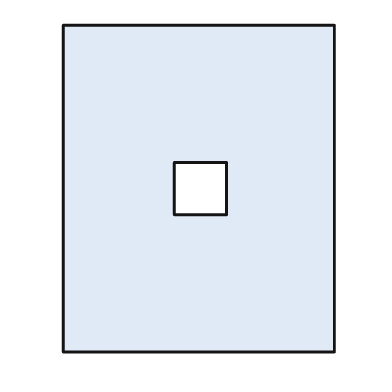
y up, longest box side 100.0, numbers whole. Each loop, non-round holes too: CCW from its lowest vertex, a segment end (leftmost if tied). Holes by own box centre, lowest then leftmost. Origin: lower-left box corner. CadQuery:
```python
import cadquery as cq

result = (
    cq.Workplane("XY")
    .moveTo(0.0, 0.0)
    .lineTo(83.0, 0.0)
    .lineTo(83.0, 100.0)
    .lineTo(0.0, 100.0)
    .close()
    .moveTo(34.0, 42.0)
    .lineTo(50.0, 42.0)
    .lineTo(50.0, 58.0)
    .lineTo(34.0, 58.0)
    .close()
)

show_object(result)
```